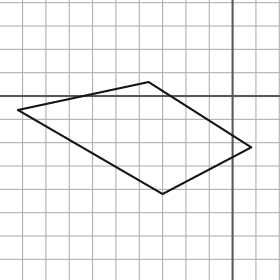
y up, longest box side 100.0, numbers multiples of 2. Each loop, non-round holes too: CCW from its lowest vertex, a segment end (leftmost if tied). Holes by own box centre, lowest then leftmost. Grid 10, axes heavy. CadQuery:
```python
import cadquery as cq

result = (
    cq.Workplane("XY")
    .moveTo(-30.0, -42.0)
    .lineTo(8.0, -22.0)
    .lineTo(-36.0, 6.0)
    .lineTo(-92.0, -6.0)
    .close()
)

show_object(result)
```